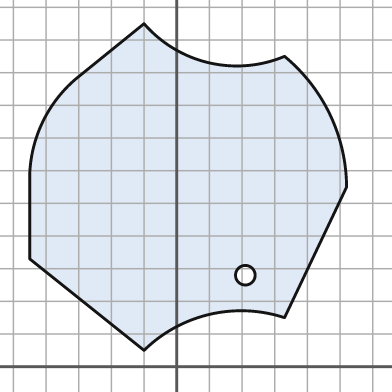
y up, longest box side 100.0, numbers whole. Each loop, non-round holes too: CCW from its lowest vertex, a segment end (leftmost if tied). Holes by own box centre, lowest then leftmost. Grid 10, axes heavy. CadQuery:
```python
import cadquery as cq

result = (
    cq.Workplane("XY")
    .moveTo(-10.0, 5.0)
    .threePointArc((10.0, 16.0), (33.0, 15.0))
    .lineTo(52.0, 55.0)
    .threePointArc((47.0, 77.0), (33.0, 95.0))
    .threePointArc((10.0, 93.0), (-10.0, 105.0))
    .lineTo(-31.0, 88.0)
    .threePointArc((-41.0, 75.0), (-45.0, 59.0))
    .lineTo(-45.0, 33.0)
    .close()
    .moveTo(21.0, 28.0)
    .circle(3.0)
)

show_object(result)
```